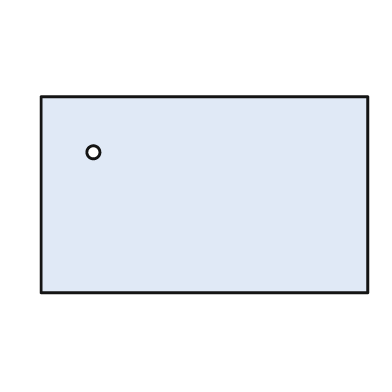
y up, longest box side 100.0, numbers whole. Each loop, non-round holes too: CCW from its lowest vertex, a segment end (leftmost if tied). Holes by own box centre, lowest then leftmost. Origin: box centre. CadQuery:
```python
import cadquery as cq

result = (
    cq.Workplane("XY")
    .moveTo(-50.0, -30.0)
    .lineTo(50.0, -30.0)
    .lineTo(50.0, 30.0)
    .lineTo(-50.0, 30.0)
    .close()
    .moveTo(-34.0, 13.0)
    .circle(2.0)
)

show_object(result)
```